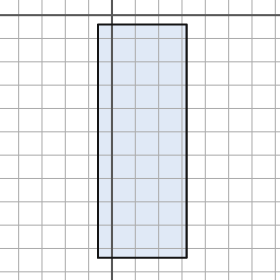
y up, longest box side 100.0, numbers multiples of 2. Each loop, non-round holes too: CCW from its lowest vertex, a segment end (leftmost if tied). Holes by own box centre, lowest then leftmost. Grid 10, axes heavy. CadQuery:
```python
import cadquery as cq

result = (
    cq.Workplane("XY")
    .moveTo(-6.0, -104.0)
    .lineTo(32.0, -104.0)
    .lineTo(32.0, -4.0)
    .lineTo(-6.0, -4.0)
    .close()
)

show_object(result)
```